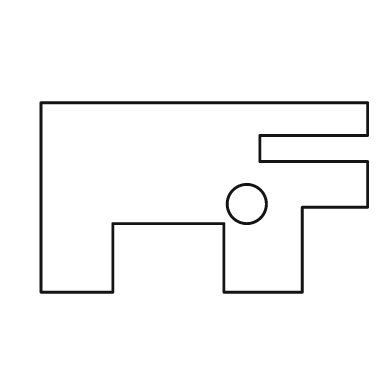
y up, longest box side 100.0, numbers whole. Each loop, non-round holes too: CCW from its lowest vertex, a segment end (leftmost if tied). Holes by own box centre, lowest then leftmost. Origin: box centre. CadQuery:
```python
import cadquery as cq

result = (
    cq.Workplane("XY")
    .moveTo(-50.0, -29.0)
    .lineTo(-28.0, -29.0)
    .lineTo(-28.0, -8.0)
    .lineTo(6.0, -8.0)
    .lineTo(6.0, -29.0)
    .lineTo(30.0, -29.0)
    .lineTo(30.0, -3.0)
    .lineTo(50.0, -3.0)
    .lineTo(50.0, 11.0)
    .lineTo(17.0, 11.0)
    .lineTo(17.0, 19.0)
    .lineTo(50.0, 19.0)
    .lineTo(50.0, 29.0)
    .lineTo(-50.0, 29.0)
    .close()
    .moveTo(13.0, -2.0)
    .circle(6.0)
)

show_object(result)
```